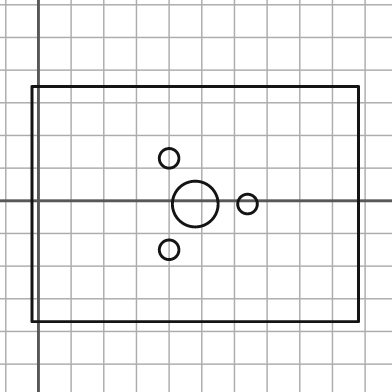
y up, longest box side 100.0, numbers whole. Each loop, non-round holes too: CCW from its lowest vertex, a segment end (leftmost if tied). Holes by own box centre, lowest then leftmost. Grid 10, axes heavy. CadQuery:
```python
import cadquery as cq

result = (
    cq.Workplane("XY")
    .moveTo(-2.0, -37.0)
    .lineTo(98.0, -37.0)
    .lineTo(98.0, 35.0)
    .lineTo(-2.0, 35.0)
    .close()
    .moveTo(40.0, -15.0)
    .circle(3.0)
    .moveTo(48.0, -1.0)
    .circle(7.0)
    .moveTo(64.0, -1.0)
    .circle(3.0)
    .moveTo(40.0, 13.0)
    .circle(3.0)
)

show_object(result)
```